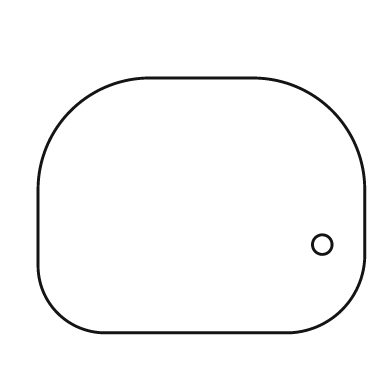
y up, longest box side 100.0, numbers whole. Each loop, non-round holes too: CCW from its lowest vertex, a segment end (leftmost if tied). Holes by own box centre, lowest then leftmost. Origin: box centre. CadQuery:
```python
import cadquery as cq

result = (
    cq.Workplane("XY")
    .moveTo(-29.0, -39.0)
    .lineTo(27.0, -39.0)
    .threePointArc((43.0, -32.0), (50.0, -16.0))
    .lineTo(50.0, 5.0)
    .threePointArc((40.0, 29.0), (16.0, 39.0))
    .lineTo(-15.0, 39.0)
    .threePointArc((-40.0, 29.0), (-50.0, 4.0))
    .lineTo(-50.0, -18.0)
    .threePointArc((-44.0, -33.0), (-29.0, -39.0))
    .close()
    .moveTo(37.0, -12.0)
    .circle(3.0)
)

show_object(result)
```